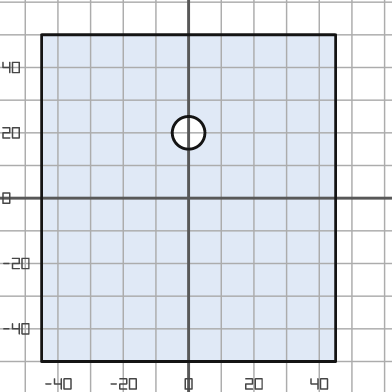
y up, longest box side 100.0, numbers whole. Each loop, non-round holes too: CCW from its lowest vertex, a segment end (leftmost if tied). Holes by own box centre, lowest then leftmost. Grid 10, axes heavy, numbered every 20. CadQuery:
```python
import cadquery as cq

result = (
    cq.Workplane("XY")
    .moveTo(-45.0, -50.0)
    .lineTo(45.0, -50.0)
    .lineTo(45.0, 50.0)
    .lineTo(-45.0, 50.0)
    .close()
    .moveTo(0.0, 20.0)
    .circle(5.0)
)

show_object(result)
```